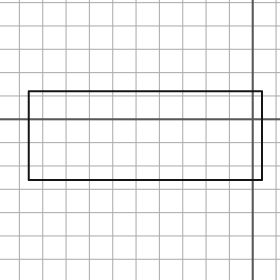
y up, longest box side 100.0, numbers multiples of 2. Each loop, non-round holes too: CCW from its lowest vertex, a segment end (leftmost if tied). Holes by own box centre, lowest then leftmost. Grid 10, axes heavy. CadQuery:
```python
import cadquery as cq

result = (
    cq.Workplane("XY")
    .moveTo(-96.0, -26.0)
    .lineTo(4.0, -26.0)
    .lineTo(4.0, 12.0)
    .lineTo(-96.0, 12.0)
    .close()
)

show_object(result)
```